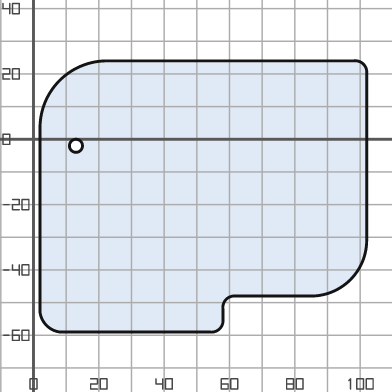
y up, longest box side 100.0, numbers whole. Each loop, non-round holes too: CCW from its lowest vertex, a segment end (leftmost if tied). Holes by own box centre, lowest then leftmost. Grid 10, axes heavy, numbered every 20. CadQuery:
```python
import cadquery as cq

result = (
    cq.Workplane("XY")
    .moveTo(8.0, -59.0)
    .lineTo(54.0, -59.0)
    .threePointArc((57.0, -58.0), (58.0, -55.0))
    .lineTo(58.0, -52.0)
    .threePointArc((59.0, -49.0), (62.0, -48.0))
    .lineTo(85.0, -48.0)
    .threePointArc((97.0, -43.0), (102.0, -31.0))
    .lineTo(102.0, 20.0)
    .threePointArc((101.0, 23.0), (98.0, 24.0))
    .lineTo(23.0, 24.0)
    .threePointArc((8.0, 18.0), (2.0, 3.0))
    .lineTo(2.0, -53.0)
    .threePointArc((4.0, -57.0), (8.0, -59.0))
    .close()
    .moveTo(13.0, -2.0)
    .circle(2.0)
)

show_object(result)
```